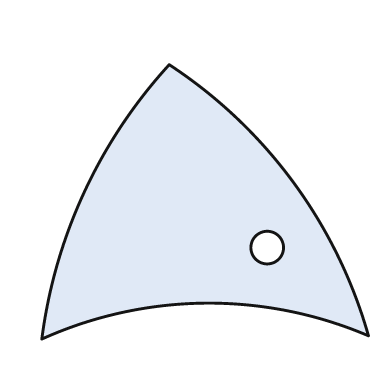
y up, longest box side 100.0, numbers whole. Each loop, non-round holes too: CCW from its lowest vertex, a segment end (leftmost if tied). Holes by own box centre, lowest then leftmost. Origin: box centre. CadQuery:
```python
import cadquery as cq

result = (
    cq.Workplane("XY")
    .moveTo(-50.0, -42.0)
    .threePointArc((0.0, -31.0), (50.0, -41.0))
    .threePointArc((27.0, 6.0), (-11.0, 42.0))
    .threePointArc((-37.0, 3.0), (-50.0, -42.0))
    .close()
    .moveTo(19.0, -14.0)
    .circle(5.0)
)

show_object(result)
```